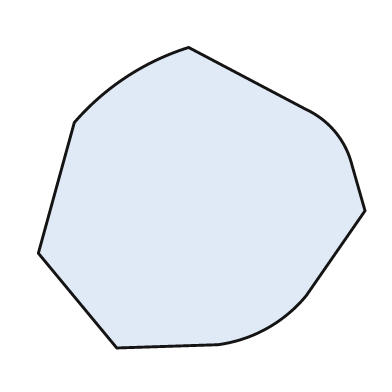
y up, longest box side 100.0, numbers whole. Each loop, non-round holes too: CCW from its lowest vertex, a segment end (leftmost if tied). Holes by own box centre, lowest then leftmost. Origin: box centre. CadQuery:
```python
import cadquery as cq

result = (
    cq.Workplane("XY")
    .moveTo(-26.0, -46.0)
    .lineTo(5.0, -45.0)
    .threePointArc((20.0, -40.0), (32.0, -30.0))
    .lineTo(50.0, -4.0)
    .lineTo(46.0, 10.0)
    .threePointArc((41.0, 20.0), (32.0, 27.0))
    .lineTo(-4.0, 46.0)
    .threePointArc((-23.0, 37.0), (-39.0, 23.0))
    .lineTo(-50.0, -17.0)
    .close()
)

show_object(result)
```